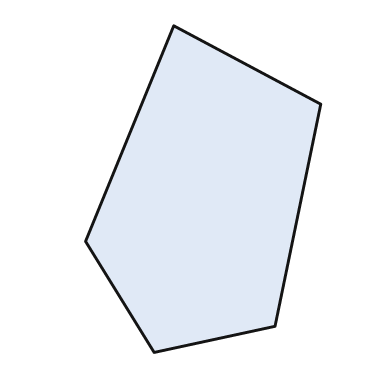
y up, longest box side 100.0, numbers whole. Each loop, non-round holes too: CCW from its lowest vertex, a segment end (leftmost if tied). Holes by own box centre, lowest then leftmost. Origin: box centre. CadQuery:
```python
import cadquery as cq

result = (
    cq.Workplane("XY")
    .moveTo(-15.0, -50.0)
    .lineTo(22.0, -42.0)
    .lineTo(36.0, 26.0)
    .lineTo(-9.0, 50.0)
    .lineTo(-36.0, -16.0)
    .close()
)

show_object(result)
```